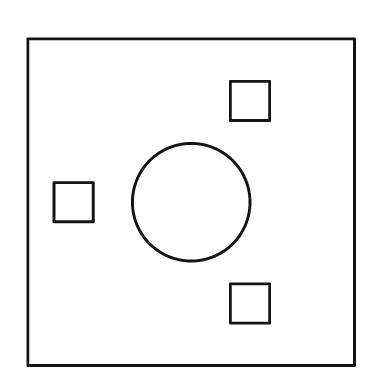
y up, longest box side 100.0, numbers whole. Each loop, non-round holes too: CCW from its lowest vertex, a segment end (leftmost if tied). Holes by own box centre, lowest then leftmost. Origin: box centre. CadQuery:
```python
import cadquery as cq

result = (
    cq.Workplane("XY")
    .moveTo(-50.0, -50.0)
    .lineTo(50.0, -50.0)
    .lineTo(50.0, 50.0)
    .lineTo(-50.0, 50.0)
    .close()
    .moveTo(12.0, -37.0)
    .lineTo(24.0, -37.0)
    .lineTo(24.0, -25.0)
    .lineTo(12.0, -25.0)
    .close()
    .moveTo(-42.0, -6.0)
    .lineTo(-30.0, -6.0)
    .lineTo(-30.0, 6.0)
    .lineTo(-42.0, 6.0)
    .close()
    .moveTo(0.0, 0.0)
    .circle(18.0)
    .moveTo(12.0, 25.0)
    .lineTo(24.0, 25.0)
    .lineTo(24.0, 37.0)
    .lineTo(12.0, 37.0)
    .close()
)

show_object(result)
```